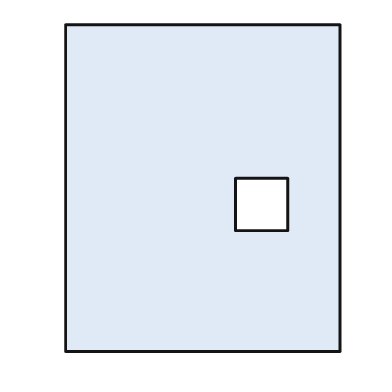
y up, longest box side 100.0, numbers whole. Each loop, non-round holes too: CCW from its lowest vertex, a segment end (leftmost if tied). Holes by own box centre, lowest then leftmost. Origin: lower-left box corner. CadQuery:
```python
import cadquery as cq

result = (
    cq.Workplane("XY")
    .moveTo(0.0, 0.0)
    .lineTo(84.0, 0.0)
    .lineTo(84.0, 100.0)
    .lineTo(0.0, 100.0)
    .close()
    .moveTo(52.0, 37.0)
    .lineTo(68.0, 37.0)
    .lineTo(68.0, 53.0)
    .lineTo(52.0, 53.0)
    .close()
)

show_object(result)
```